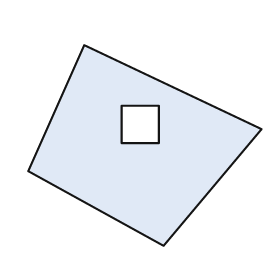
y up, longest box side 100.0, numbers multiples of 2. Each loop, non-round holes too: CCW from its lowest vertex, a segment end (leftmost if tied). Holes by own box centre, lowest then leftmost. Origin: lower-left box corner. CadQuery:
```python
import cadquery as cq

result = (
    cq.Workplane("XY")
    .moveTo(58.0, 0.0)
    .lineTo(100.0, 50.0)
    .lineTo(24.0, 86.0)
    .lineTo(0.0, 32.0)
    .close()
    .moveTo(40.0, 44.0)
    .lineTo(56.0, 44.0)
    .lineTo(56.0, 60.0)
    .lineTo(40.0, 60.0)
    .close()
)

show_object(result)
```